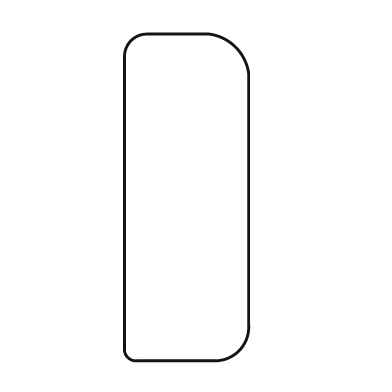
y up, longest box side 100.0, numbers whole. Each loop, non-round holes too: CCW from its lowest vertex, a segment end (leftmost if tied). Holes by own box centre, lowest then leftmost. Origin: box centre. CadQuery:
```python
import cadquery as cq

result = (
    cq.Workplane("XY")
    .moveTo(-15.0, -50.0)
    .lineTo(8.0, -50.0)
    .threePointArc((16.0, -47.0), (19.0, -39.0))
    .lineTo(19.0, 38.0)
    .threePointArc((15.0, 46.0), (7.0, 50.0))
    .lineTo(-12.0, 50.0)
    .threePointArc((-17.0, 48.0), (-19.0, 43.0))
    .lineTo(-19.0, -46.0)
    .threePointArc((-18.0, -49.0), (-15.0, -50.0))
    .close()
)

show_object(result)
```